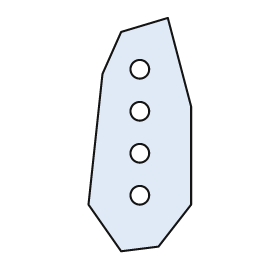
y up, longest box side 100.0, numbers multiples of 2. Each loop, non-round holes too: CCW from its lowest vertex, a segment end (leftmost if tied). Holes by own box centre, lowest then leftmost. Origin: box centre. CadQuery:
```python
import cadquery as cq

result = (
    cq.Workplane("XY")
    .moveTo(-8.0, -50.0)
    .lineTo(8.0, -48.0)
    .lineTo(22.0, -30.0)
    .lineTo(22.0, 12.0)
    .lineTo(12.0, 50.0)
    .lineTo(-8.0, 44.0)
    .lineTo(-16.0, 26.0)
    .lineTo(-22.0, -30.0)
    .close()
    .moveTo(0.0, -26.0)
    .circle(4.0)
    .moveTo(0.0, -8.0)
    .circle(4.0)
    .moveTo(0.0, 10.0)
    .circle(4.0)
    .moveTo(0.0, 28.0)
    .circle(4.0)
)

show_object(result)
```